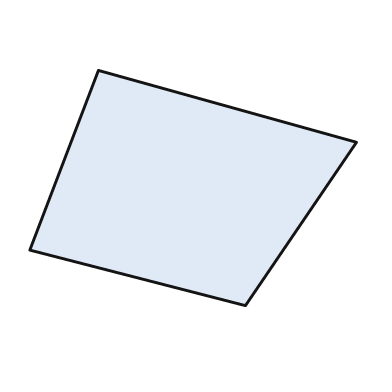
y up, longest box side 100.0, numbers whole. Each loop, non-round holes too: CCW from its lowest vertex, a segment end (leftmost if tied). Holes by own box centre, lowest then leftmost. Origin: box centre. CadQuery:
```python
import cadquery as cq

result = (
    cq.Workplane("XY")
    .moveTo(16.0, -36.0)
    .lineTo(50.0, 14.0)
    .lineTo(-29.0, 36.0)
    .lineTo(-50.0, -19.0)
    .close()
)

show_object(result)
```